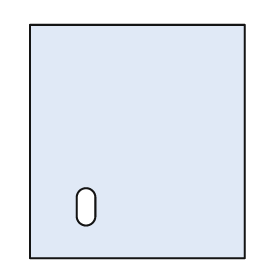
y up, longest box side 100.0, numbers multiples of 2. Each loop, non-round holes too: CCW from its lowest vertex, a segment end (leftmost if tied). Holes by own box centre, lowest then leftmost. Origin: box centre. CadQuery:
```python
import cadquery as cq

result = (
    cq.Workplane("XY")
    .moveTo(-46.0, -50.0)
    .lineTo(46.0, -50.0)
    .lineTo(46.0, 50.0)
    .lineTo(-46.0, 50.0)
    .close()
    .moveTo(-26.0, -32.0)
    .threePointArc((-22.0, -36.0), (-18.0, -32.0))
    .lineTo(-18.0, -24.0)
    .threePointArc((-22.0, -20.0), (-26.0, -24.0))
    .close()
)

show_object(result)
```